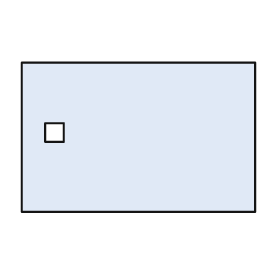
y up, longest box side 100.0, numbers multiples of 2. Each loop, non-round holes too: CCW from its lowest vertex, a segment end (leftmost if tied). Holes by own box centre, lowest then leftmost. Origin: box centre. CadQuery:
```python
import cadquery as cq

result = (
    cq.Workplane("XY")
    .moveTo(-50.0, -32.0)
    .lineTo(50.0, -32.0)
    .lineTo(50.0, 32.0)
    .lineTo(-50.0, 32.0)
    .close()
    .moveTo(-40.0, -2.0)
    .lineTo(-32.0, -2.0)
    .lineTo(-32.0, 6.0)
    .lineTo(-40.0, 6.0)
    .close()
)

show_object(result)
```